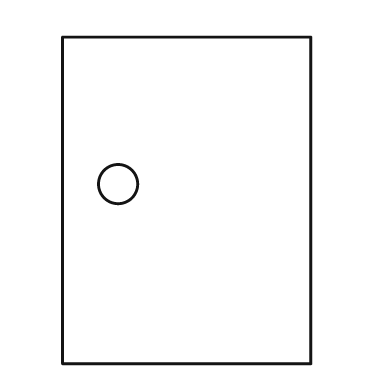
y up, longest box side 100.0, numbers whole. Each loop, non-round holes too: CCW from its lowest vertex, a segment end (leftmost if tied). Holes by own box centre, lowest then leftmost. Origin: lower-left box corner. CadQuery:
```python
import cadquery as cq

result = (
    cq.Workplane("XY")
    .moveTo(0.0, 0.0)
    .lineTo(76.0, 0.0)
    .lineTo(76.0, 100.0)
    .lineTo(0.0, 100.0)
    .close()
    .moveTo(17.0, 55.0)
    .circle(6.0)
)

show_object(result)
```